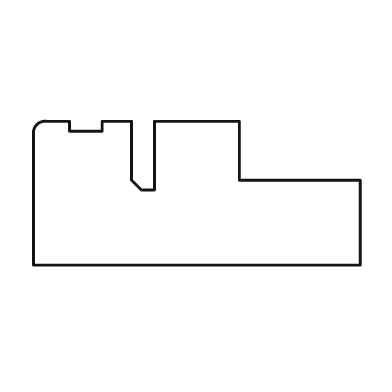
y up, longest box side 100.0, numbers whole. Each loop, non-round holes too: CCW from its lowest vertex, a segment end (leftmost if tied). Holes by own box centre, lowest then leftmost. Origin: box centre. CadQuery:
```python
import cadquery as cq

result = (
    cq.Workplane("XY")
    .moveTo(-50.0, -22.0)
    .lineTo(50.0, -22.0)
    .lineTo(50.0, 4.0)
    .lineTo(13.0, 4.0)
    .lineTo(13.0, 22.0)
    .lineTo(-13.0, 22.0)
    .lineTo(-13.0, 1.0)
    .lineTo(-17.0, 1.0)
    .lineTo(-20.0, 4.0)
    .lineTo(-20.0, 22.0)
    .lineTo(-29.0, 22.0)
    .lineTo(-29.0, 19.0)
    .lineTo(-39.0, 19.0)
    .lineTo(-39.0, 22.0)
    .lineTo(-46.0, 22.0)
    .threePointArc((-49.0, 21.0), (-50.0, 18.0))
    .close()
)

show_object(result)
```